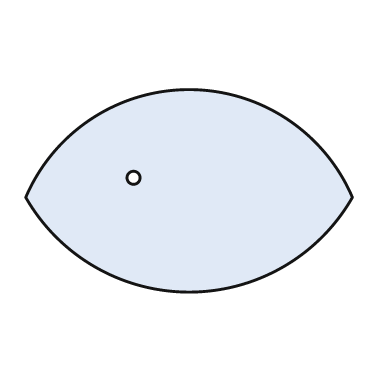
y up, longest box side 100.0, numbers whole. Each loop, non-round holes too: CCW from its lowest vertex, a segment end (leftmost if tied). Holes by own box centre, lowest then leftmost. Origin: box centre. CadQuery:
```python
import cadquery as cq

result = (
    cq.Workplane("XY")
    .moveTo(-50.0, -2.0)
    .threePointArc((0.0, -31.0), (50.0, -2.0))
    .threePointArc((0.0, 31.0), (-50.0, -2.0))
    .close()
    .moveTo(-17.0, 4.0)
    .circle(2.0)
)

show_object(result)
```